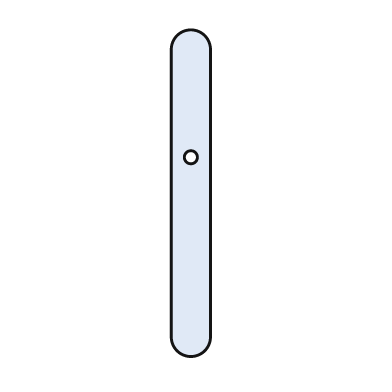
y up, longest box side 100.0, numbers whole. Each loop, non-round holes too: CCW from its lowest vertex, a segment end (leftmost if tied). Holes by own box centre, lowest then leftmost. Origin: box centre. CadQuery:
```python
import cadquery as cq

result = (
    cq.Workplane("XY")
    .moveTo(-6.0, -44.0)
    .threePointArc((0.0, -50.0), (6.0, -44.0))
    .lineTo(6.0, 44.0)
    .threePointArc((0.0, 50.0), (-6.0, 44.0))
    .close()
    .moveTo(0.0, 11.0)
    .circle(2.0)
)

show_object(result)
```